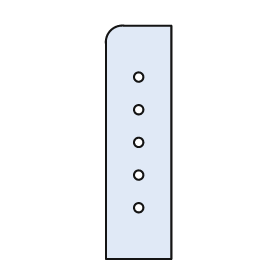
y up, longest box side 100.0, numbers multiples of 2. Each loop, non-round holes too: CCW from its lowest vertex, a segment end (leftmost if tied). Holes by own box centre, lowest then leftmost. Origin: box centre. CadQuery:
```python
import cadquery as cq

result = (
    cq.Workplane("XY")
    .moveTo(-14.0, -50.0)
    .lineTo(14.0, -50.0)
    .lineTo(14.0, 50.0)
    .lineTo(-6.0, 50.0)
    .threePointArc((-12.0, 48.0), (-14.0, 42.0))
    .close()
    .moveTo(0.0, -28.0)
    .circle(2.0)
    .moveTo(0.0, -14.0)
    .circle(2.0)
    .moveTo(0.0, 0.0)
    .circle(2.0)
    .moveTo(0.0, 14.0)
    .circle(2.0)
    .moveTo(0.0, 28.0)
    .circle(2.0)
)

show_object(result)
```